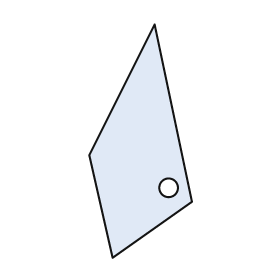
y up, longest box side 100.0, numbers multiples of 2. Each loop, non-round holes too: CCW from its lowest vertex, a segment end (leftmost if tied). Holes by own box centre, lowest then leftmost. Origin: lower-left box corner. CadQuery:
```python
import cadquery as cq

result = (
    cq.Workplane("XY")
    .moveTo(10.0, 0.0)
    .lineTo(44.0, 24.0)
    .lineTo(28.0, 100.0)
    .lineTo(0.0, 44.0)
    .close()
    .moveTo(34.0, 30.0)
    .circle(4.0)
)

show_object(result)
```